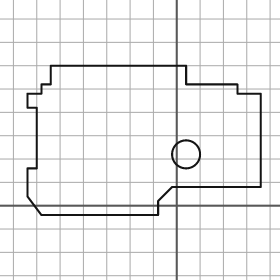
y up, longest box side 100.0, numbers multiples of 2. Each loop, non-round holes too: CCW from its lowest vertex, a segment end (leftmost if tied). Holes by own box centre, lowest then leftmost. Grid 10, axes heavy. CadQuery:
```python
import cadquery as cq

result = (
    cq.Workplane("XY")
    .moveTo(-58.0, -4.0)
    .lineTo(-8.0, -4.0)
    .lineTo(-8.0, 2.0)
    .lineTo(-2.0, 8.0)
    .lineTo(36.0, 8.0)
    .lineTo(36.0, 48.0)
    .lineTo(26.0, 48.0)
    .lineTo(26.0, 52.0)
    .lineTo(4.0, 52.0)
    .lineTo(4.0, 60.0)
    .lineTo(-54.0, 60.0)
    .lineTo(-54.0, 52.0)
    .lineTo(-58.0, 52.0)
    .lineTo(-58.0, 48.0)
    .lineTo(-64.0, 48.0)
    .lineTo(-64.0, 42.0)
    .lineTo(-60.0, 42.0)
    .lineTo(-60.0, 16.0)
    .lineTo(-64.0, 16.0)
    .lineTo(-64.0, 4.0)
    .close()
    .moveTo(4.0, 22.0)
    .circle(6.0)
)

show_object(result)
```